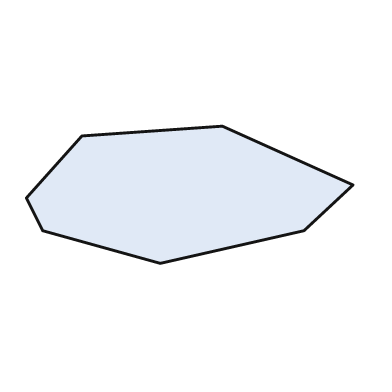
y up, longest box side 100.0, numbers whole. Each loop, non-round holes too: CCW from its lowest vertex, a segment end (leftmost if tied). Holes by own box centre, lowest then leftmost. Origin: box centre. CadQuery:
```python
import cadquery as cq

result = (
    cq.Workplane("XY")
    .moveTo(-9.0, -21.0)
    .lineTo(35.0, -11.0)
    .lineTo(50.0, 3.0)
    .lineTo(10.0, 21.0)
    .lineTo(-33.0, 18.0)
    .lineTo(-50.0, -1.0)
    .lineTo(-45.0, -11.0)
    .close()
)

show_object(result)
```